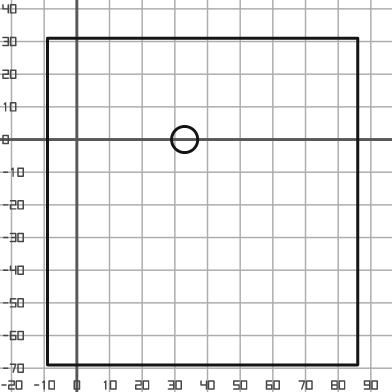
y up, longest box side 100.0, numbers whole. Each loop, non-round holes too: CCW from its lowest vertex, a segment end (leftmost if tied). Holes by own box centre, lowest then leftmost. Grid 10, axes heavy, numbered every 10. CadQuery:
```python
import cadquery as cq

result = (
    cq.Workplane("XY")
    .moveTo(-9.0, -69.0)
    .lineTo(86.0, -69.0)
    .lineTo(86.0, 31.0)
    .lineTo(-9.0, 31.0)
    .close()
    .moveTo(33.0, 0.0)
    .circle(4.0)
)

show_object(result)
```